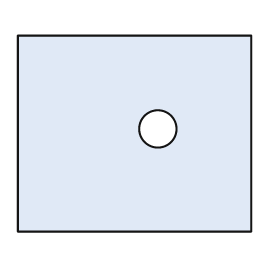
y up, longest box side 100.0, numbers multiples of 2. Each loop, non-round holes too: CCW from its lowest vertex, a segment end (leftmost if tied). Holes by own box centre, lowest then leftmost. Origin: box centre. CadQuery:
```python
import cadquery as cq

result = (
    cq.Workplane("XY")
    .moveTo(-50.0, -42.0)
    .lineTo(50.0, -42.0)
    .lineTo(50.0, 42.0)
    .lineTo(-50.0, 42.0)
    .close()
    .moveTo(10.0, 2.0)
    .circle(8.0)
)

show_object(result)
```